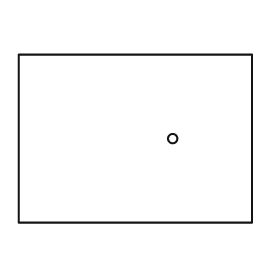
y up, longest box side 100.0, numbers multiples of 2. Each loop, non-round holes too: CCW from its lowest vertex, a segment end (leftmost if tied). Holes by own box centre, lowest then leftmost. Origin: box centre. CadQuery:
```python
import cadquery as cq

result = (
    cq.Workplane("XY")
    .moveTo(-50.0, -36.0)
    .lineTo(50.0, -36.0)
    .lineTo(50.0, 36.0)
    .lineTo(-50.0, 36.0)
    .close()
    .moveTo(16.0, 0.0)
    .circle(2.0)
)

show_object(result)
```